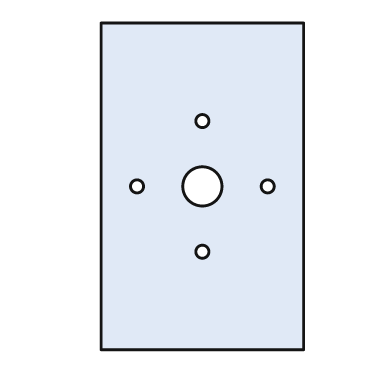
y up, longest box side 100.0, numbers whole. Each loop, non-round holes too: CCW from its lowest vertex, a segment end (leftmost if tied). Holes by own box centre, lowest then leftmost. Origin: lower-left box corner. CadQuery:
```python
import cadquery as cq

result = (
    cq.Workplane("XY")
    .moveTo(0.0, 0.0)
    .lineTo(62.0, 0.0)
    .lineTo(62.0, 100.0)
    .lineTo(0.0, 100.0)
    .close()
    .moveTo(31.0, 30.0)
    .circle(2.0)
    .moveTo(11.0, 50.0)
    .circle(2.0)
    .moveTo(31.0, 50.0)
    .circle(6.0)
    .moveTo(51.0, 50.0)
    .circle(2.0)
    .moveTo(31.0, 70.0)
    .circle(2.0)
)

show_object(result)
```